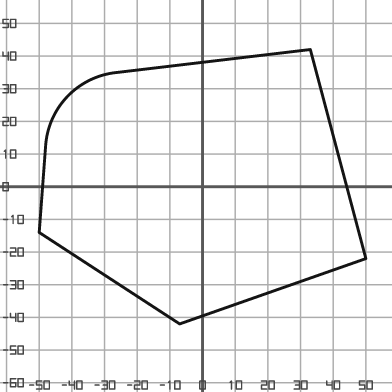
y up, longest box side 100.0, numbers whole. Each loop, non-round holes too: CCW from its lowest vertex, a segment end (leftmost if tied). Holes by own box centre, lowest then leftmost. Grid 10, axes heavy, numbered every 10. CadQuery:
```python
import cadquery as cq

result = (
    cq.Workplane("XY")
    .moveTo(-7.0, -42.0)
    .lineTo(50.0, -22.0)
    .lineTo(33.0, 42.0)
    .lineTo(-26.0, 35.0)
    .threePointArc((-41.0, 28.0), (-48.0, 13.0))
    .lineTo(-50.0, -14.0)
    .close()
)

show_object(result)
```